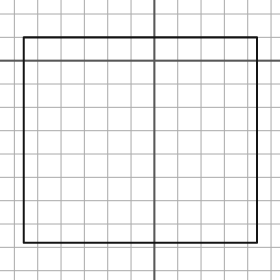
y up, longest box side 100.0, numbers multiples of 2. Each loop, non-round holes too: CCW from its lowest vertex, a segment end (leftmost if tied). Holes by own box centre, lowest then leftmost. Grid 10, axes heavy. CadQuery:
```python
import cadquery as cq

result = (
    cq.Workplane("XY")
    .moveTo(-56.0, -78.0)
    .lineTo(44.0, -78.0)
    .lineTo(44.0, 10.0)
    .lineTo(-56.0, 10.0)
    .close()
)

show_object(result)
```